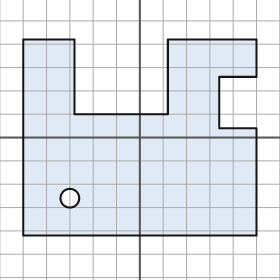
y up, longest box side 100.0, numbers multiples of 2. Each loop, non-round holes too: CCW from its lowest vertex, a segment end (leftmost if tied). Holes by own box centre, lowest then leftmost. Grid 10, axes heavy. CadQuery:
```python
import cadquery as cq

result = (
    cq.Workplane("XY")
    .moveTo(-50.0, -42.0)
    .lineTo(50.0, -42.0)
    .lineTo(50.0, 4.0)
    .lineTo(34.0, 4.0)
    .lineTo(34.0, 26.0)
    .lineTo(50.0, 26.0)
    .lineTo(50.0, 42.0)
    .lineTo(12.0, 42.0)
    .lineTo(12.0, 10.0)
    .lineTo(-28.0, 10.0)
    .lineTo(-28.0, 42.0)
    .lineTo(-50.0, 42.0)
    .close()
    .moveTo(-30.0, -26.0)
    .circle(4.0)
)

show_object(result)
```